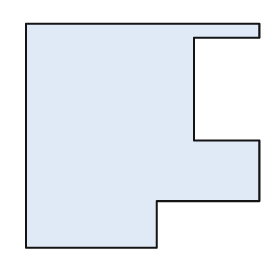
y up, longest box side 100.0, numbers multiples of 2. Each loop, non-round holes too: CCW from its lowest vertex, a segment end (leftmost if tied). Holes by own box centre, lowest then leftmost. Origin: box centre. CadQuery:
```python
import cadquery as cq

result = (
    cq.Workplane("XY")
    .moveTo(-50.0, -48.0)
    .lineTo(6.0, -48.0)
    .lineTo(6.0, -28.0)
    .lineTo(50.0, -28.0)
    .lineTo(50.0, -2.0)
    .lineTo(22.0, -2.0)
    .lineTo(22.0, 42.0)
    .lineTo(50.0, 42.0)
    .lineTo(50.0, 48.0)
    .lineTo(-50.0, 48.0)
    .close()
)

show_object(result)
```